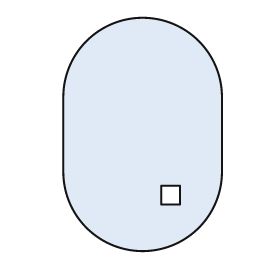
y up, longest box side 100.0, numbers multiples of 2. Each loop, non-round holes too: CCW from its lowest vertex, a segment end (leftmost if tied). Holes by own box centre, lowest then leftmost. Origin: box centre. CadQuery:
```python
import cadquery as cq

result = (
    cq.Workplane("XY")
    .moveTo(-34.0, -16.0)
    .threePointArc((0.0, -50.0), (34.0, -16.0))
    .lineTo(34.0, 16.0)
    .threePointArc((0.0, 50.0), (-34.0, 16.0))
    .close()
    .moveTo(8.0, -30.0)
    .lineTo(16.0, -30.0)
    .lineTo(16.0, -22.0)
    .lineTo(8.0, -22.0)
    .close()
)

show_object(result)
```